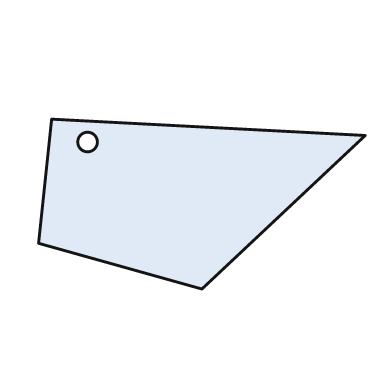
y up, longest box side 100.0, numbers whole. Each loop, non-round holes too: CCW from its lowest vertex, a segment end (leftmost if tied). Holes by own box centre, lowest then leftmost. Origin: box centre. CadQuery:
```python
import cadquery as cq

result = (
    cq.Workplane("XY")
    .moveTo(0.0, -26.0)
    .lineTo(50.0, 21.0)
    .lineTo(-46.0, 26.0)
    .lineTo(-50.0, -12.0)
    .close()
    .moveTo(-35.0, 19.0)
    .circle(3.0)
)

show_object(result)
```